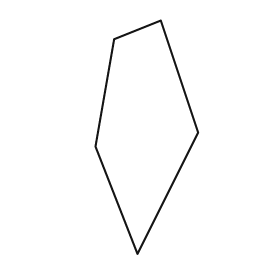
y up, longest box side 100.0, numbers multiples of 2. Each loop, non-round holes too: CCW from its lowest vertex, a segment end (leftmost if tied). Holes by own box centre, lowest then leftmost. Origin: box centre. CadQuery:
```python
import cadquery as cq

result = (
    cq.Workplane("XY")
    .moveTo(-4.0, -50.0)
    .lineTo(22.0, 2.0)
    .lineTo(6.0, 50.0)
    .lineTo(-14.0, 42.0)
    .lineTo(-22.0, -4.0)
    .close()
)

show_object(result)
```